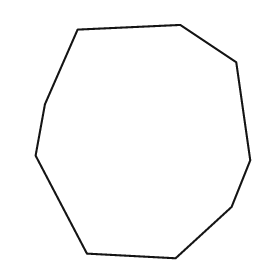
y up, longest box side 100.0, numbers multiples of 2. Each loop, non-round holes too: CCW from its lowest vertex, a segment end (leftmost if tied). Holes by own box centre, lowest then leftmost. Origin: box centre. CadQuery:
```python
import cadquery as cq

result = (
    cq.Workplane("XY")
    .moveTo(14.0, -50.0)
    .lineTo(38.0, -28.0)
    .lineTo(46.0, -8.0)
    .lineTo(40.0, 34.0)
    .lineTo(16.0, 50.0)
    .lineTo(-28.0, 48.0)
    .lineTo(-42.0, 16.0)
    .lineTo(-46.0, -6.0)
    .lineTo(-24.0, -48.0)
    .close()
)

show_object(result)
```